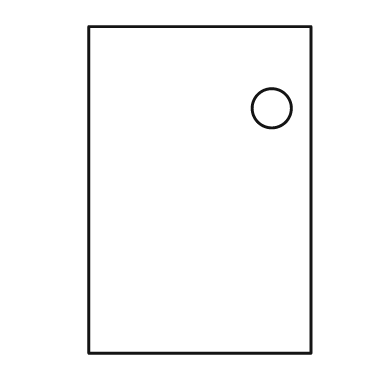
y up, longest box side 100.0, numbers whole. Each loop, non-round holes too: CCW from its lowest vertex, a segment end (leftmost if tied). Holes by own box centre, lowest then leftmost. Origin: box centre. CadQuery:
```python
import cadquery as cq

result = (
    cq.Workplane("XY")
    .moveTo(-34.0, -50.0)
    .lineTo(34.0, -50.0)
    .lineTo(34.0, 50.0)
    .lineTo(-34.0, 50.0)
    .close()
    .moveTo(22.0, 25.0)
    .circle(6.0)
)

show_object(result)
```